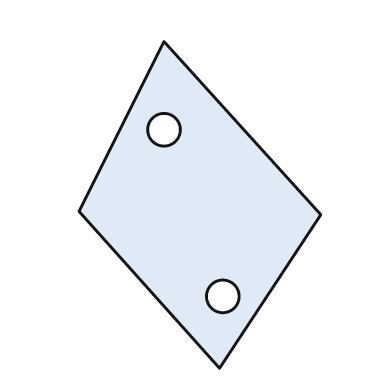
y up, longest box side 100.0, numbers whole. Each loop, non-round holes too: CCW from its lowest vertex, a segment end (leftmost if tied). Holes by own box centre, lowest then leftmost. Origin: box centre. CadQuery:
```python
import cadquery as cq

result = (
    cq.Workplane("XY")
    .moveTo(6.0, -50.0)
    .lineTo(37.0, -3.0)
    .lineTo(-11.0, 50.0)
    .lineTo(-37.0, -2.0)
    .close()
    .moveTo(7.0, -28.0)
    .circle(5.0)
    .moveTo(-11.0, 23.0)
    .circle(5.0)
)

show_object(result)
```